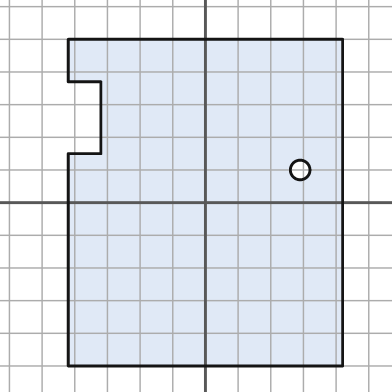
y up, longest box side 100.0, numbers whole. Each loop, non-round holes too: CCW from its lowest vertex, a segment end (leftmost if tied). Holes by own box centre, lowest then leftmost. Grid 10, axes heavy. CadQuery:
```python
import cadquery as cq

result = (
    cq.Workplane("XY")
    .moveTo(-42.0, -50.0)
    .lineTo(42.0, -50.0)
    .lineTo(42.0, 50.0)
    .lineTo(-42.0, 50.0)
    .lineTo(-42.0, 37.0)
    .lineTo(-32.0, 37.0)
    .lineTo(-32.0, 15.0)
    .lineTo(-42.0, 15.0)
    .close()
    .moveTo(29.0, 10.0)
    .circle(3.0)
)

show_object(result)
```